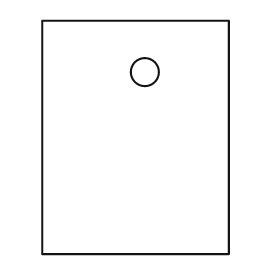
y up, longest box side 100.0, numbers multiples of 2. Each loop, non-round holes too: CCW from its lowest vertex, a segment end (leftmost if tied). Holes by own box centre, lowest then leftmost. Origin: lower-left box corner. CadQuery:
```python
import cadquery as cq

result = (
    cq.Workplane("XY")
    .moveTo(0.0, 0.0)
    .lineTo(80.0, 0.0)
    .lineTo(80.0, 100.0)
    .lineTo(0.0, 100.0)
    .close()
    .moveTo(44.0, 78.0)
    .circle(6.0)
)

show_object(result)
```